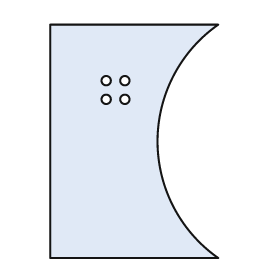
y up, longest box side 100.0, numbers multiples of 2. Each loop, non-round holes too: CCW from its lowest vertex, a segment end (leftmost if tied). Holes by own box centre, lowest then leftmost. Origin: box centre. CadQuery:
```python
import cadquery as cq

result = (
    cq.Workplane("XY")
    .moveTo(-36.0, -50.0)
    .lineTo(36.0, -50.0)
    .threePointArc((10.0, 0.0), (36.0, 50.0))
    .lineTo(-36.0, 50.0)
    .close()
    .moveTo(-12.0, 18.0)
    .circle(2.0)
    .moveTo(-4.0, 18.0)
    .circle(2.0)
    .moveTo(-12.0, 26.0)
    .circle(2.0)
    .moveTo(-4.0, 26.0)
    .circle(2.0)
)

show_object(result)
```